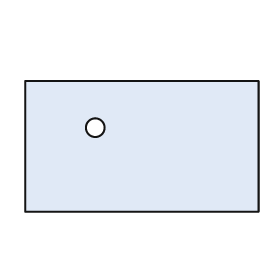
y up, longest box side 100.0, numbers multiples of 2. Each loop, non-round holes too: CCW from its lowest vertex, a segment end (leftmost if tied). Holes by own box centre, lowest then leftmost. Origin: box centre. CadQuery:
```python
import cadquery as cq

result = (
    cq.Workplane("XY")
    .moveTo(-50.0, -28.0)
    .lineTo(50.0, -28.0)
    .lineTo(50.0, 28.0)
    .lineTo(-50.0, 28.0)
    .close()
    .moveTo(-20.0, 8.0)
    .circle(4.0)
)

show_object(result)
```